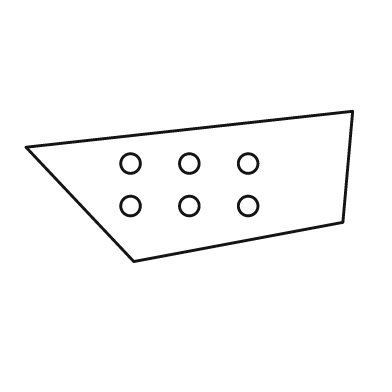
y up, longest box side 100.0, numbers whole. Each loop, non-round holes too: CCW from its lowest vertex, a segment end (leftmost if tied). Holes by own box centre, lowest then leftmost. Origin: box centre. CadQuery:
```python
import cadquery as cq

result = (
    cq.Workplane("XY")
    .moveTo(-17.0, -23.0)
    .lineTo(47.0, -11.0)
    .lineTo(50.0, 23.0)
    .lineTo(-50.0, 12.0)
    .close()
    .moveTo(-18.0, -6.0)
    .circle(3.0)
    .moveTo(0.0, -6.0)
    .circle(3.0)
    .moveTo(18.0, -6.0)
    .circle(3.0)
    .moveTo(-18.0, 7.0)
    .circle(3.0)
    .moveTo(0.0, 7.0)
    .circle(3.0)
    .moveTo(18.0, 7.0)
    .circle(3.0)
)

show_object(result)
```